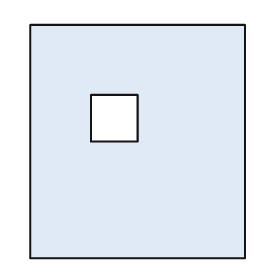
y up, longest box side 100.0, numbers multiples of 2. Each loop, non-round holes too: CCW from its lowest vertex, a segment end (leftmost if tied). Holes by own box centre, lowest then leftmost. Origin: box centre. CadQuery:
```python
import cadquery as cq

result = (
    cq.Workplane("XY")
    .moveTo(-46.0, -50.0)
    .lineTo(46.0, -50.0)
    .lineTo(46.0, 50.0)
    .lineTo(-46.0, 50.0)
    .close()
    .moveTo(-20.0, 0.0)
    .lineTo(0.0, 0.0)
    .lineTo(0.0, 20.0)
    .lineTo(-20.0, 20.0)
    .close()
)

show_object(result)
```